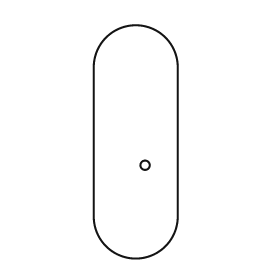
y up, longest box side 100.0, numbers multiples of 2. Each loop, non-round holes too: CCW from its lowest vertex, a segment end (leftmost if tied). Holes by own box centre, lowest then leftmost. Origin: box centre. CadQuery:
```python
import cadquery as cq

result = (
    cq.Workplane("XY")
    .moveTo(-18.0, -32.0)
    .threePointArc((0.0, -50.0), (18.0, -32.0))
    .lineTo(18.0, 32.0)
    .threePointArc((0.0, 50.0), (-18.0, 32.0))
    .close()
    .moveTo(4.0, -10.0)
    .circle(2.0)
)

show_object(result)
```